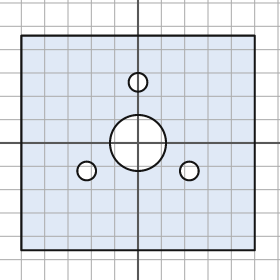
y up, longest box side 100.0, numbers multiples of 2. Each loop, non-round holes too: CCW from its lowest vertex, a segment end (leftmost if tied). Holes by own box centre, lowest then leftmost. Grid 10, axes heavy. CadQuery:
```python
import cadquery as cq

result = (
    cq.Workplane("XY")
    .moveTo(-50.0, -46.0)
    .lineTo(50.0, -46.0)
    .lineTo(50.0, 46.0)
    .lineTo(-50.0, 46.0)
    .close()
    .moveTo(-22.0, -12.0)
    .circle(4.0)
    .moveTo(22.0, -12.0)
    .circle(4.0)
    .moveTo(0.0, 0.0)
    .circle(12.0)
    .moveTo(0.0, 26.0)
    .circle(4.0)
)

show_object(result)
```